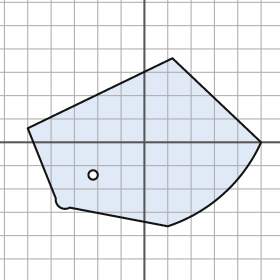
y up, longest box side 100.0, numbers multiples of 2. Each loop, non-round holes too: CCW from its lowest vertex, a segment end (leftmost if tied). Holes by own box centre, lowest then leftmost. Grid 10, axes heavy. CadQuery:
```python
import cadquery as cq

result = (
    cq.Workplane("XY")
    .moveTo(10.0, -36.0)
    .threePointArc((34.0, -22.0), (50.0, 0.0))
    .lineTo(12.0, 36.0)
    .lineTo(-50.0, 6.0)
    .lineTo(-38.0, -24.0)
    .threePointArc((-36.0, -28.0), (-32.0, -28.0))
    .close()
    .moveTo(-22.0, -14.0)
    .circle(2.0)
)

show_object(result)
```